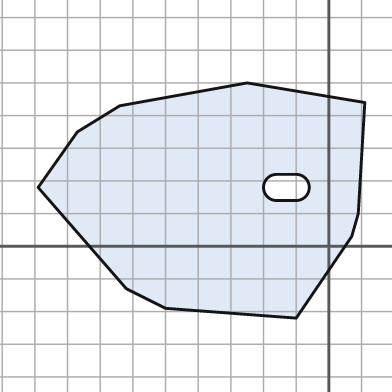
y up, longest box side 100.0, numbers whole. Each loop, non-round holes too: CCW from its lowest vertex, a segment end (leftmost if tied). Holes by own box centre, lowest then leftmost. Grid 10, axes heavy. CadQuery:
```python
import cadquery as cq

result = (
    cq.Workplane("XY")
    .moveTo(-10.0, -22.0)
    .lineTo(7.0, 3.0)
    .lineTo(9.0, 10.0)
    .lineTo(11.0, 44.0)
    .lineTo(-25.0, 50.0)
    .lineTo(-64.0, 43.0)
    .lineTo(-77.0, 35.0)
    .lineTo(-89.0, 18.0)
    .lineTo(-62.0, -13.0)
    .lineTo(-50.0, -19.0)
    .close()
    .moveTo(-16.0, 14.0)
    .lineTo(-10.0, 14.0)
    .threePointArc((-6.0, 18.0), (-10.0, 22.0))
    .lineTo(-16.0, 22.0)
    .threePointArc((-20.0, 18.0), (-16.0, 14.0))
    .close()
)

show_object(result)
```